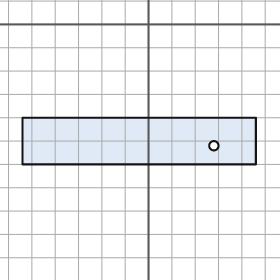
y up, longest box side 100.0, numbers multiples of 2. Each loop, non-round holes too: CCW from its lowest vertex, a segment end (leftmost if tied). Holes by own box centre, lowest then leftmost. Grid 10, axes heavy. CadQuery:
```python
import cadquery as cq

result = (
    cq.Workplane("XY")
    .moveTo(-54.0, -60.0)
    .lineTo(46.0, -60.0)
    .lineTo(46.0, -40.0)
    .lineTo(-54.0, -40.0)
    .close()
    .moveTo(28.0, -52.0)
    .circle(2.0)
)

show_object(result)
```